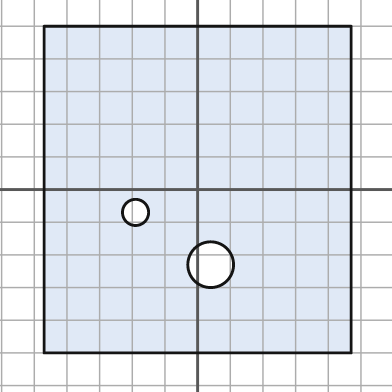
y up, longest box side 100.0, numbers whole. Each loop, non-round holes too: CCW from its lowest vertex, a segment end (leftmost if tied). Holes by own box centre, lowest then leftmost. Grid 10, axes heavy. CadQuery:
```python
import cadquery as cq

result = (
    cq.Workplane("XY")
    .moveTo(-47.0, -50.0)
    .lineTo(47.0, -50.0)
    .lineTo(47.0, 50.0)
    .lineTo(-47.0, 50.0)
    .close()
    .moveTo(4.0, -23.0)
    .circle(7.0)
    .moveTo(-19.0, -7.0)
    .circle(4.0)
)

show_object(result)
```